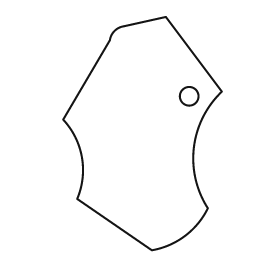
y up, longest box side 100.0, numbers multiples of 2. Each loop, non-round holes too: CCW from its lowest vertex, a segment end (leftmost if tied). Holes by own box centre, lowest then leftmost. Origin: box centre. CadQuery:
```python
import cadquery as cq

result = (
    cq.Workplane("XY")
    .moveTo(4.0, -50.0)
    .threePointArc((18.0, -44.0), (28.0, -32.0))
    .threePointArc((22.0, -6.0), (34.0, 18.0))
    .lineTo(10.0, 50.0)
    .lineTo(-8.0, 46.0)
    .threePointArc((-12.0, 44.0), (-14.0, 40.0))
    .lineTo(-34.0, 6.0)
    .threePointArc((-26.0, -10.0), (-28.0, -28.0))
    .close()
    .moveTo(20.0, 16.0)
    .circle(4.0)
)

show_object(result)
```